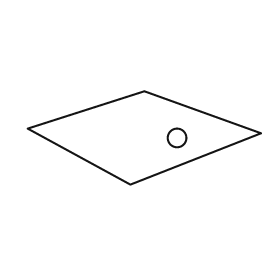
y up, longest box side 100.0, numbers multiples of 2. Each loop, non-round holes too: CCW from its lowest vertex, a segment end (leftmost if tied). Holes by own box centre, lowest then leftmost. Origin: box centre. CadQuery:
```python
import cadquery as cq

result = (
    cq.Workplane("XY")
    .moveTo(-6.0, -20.0)
    .lineTo(50.0, 2.0)
    .lineTo(0.0, 20.0)
    .lineTo(-50.0, 4.0)
    .close()
    .moveTo(14.0, 0.0)
    .circle(4.0)
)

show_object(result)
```